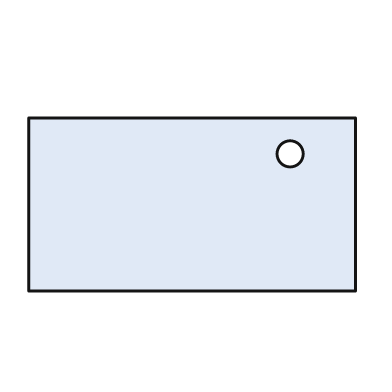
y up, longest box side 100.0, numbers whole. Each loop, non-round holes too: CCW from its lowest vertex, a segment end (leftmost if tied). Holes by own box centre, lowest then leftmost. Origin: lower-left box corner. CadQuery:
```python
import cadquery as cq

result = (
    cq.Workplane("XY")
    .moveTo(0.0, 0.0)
    .lineTo(100.0, 0.0)
    .lineTo(100.0, 53.0)
    .lineTo(0.0, 53.0)
    .close()
    .moveTo(80.0, 42.0)
    .circle(4.0)
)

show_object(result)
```